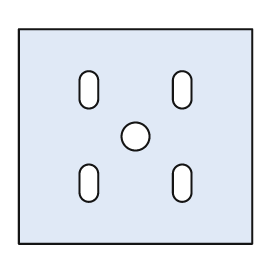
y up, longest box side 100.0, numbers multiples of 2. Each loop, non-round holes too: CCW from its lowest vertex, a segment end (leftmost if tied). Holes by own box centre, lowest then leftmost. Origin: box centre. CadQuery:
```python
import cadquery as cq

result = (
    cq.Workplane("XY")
    .moveTo(-50.0, -46.0)
    .lineTo(50.0, -46.0)
    .lineTo(50.0, 46.0)
    .lineTo(-50.0, 46.0)
    .close()
    .moveTo(-24.0, -24.0)
    .threePointArc((-20.0, -28.0), (-16.0, -24.0))
    .lineTo(-16.0, -16.0)
    .threePointArc((-20.0, -12.0), (-24.0, -16.0))
    .close()
    .moveTo(16.0, -24.0)
    .threePointArc((20.0, -28.0), (24.0, -24.0))
    .lineTo(24.0, -16.0)
    .threePointArc((20.0, -12.0), (16.0, -16.0))
    .close()
    .moveTo(0.0, 0.0)
    .circle(6.0)
    .moveTo(-24.0, 16.0)
    .threePointArc((-20.0, 12.0), (-16.0, 16.0))
    .lineTo(-16.0, 24.0)
    .threePointArc((-20.0, 28.0), (-24.0, 24.0))
    .close()
    .moveTo(16.0, 16.0)
    .threePointArc((20.0, 12.0), (24.0, 16.0))
    .lineTo(24.0, 24.0)
    .threePointArc((20.0, 28.0), (16.0, 24.0))
    .close()
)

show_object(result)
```